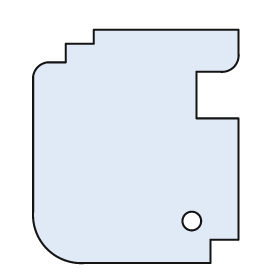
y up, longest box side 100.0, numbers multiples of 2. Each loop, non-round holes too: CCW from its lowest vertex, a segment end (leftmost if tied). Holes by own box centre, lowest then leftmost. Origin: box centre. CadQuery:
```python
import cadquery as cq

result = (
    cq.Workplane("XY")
    .moveTo(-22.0, -50.0)
    .lineTo(32.0, -50.0)
    .lineTo(32.0, -40.0)
    .lineTo(44.0, -40.0)
    .lineTo(44.0, 12.0)
    .lineTo(26.0, 12.0)
    .lineTo(26.0, 32.0)
    .lineTo(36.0, 32.0)
    .threePointArc((42.0, 34.0), (44.0, 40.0))
    .lineTo(44.0, 50.0)
    .lineTo(-18.0, 50.0)
    .lineTo(-18.0, 44.0)
    .lineTo(-30.0, 44.0)
    .lineTo(-30.0, 36.0)
    .lineTo(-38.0, 36.0)
    .threePointArc((-42.0, 34.0), (-44.0, 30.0))
    .lineTo(-44.0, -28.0)
    .threePointArc((-38.0, -44.0), (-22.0, -50.0))
    .close()
    .moveTo(24.0, -32.0)
    .circle(4.0)
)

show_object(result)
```